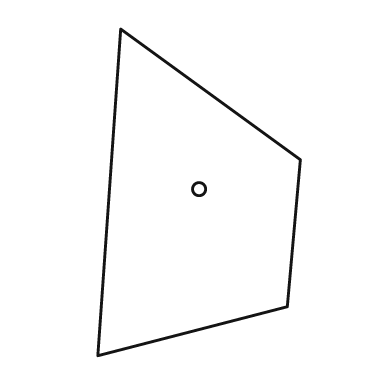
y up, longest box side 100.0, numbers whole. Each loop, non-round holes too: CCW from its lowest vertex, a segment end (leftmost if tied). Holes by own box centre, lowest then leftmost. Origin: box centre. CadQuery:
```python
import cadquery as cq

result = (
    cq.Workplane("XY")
    .moveTo(-31.0, -50.0)
    .lineTo(27.0, -35.0)
    .lineTo(31.0, 10.0)
    .lineTo(-24.0, 50.0)
    .close()
    .moveTo(0.0, 1.0)
    .circle(2.0)
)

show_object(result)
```